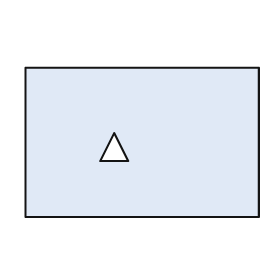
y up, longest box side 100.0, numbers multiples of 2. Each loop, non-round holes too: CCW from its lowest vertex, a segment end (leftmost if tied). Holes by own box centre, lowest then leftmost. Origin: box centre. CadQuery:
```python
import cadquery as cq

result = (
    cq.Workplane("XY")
    .moveTo(-50.0, -32.0)
    .lineTo(50.0, -32.0)
    .lineTo(50.0, 32.0)
    .lineTo(-50.0, 32.0)
    .close()
    .moveTo(-18.0, -8.0)
    .lineTo(-6.0, -8.0)
    .lineTo(-12.0, 4.0)
    .close()
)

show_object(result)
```